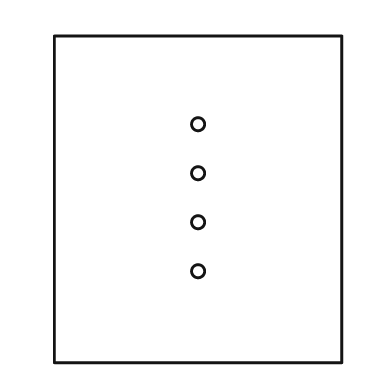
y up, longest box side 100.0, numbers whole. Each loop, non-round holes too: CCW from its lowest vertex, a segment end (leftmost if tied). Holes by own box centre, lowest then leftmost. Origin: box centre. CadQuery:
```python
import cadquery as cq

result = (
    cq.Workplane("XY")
    .moveTo(-44.0, -50.0)
    .lineTo(44.0, -50.0)
    .lineTo(44.0, 50.0)
    .lineTo(-44.0, 50.0)
    .close()
    .moveTo(0.0, -22.0)
    .circle(2.0)
    .moveTo(0.0, -7.0)
    .circle(2.0)
    .moveTo(0.0, 8.0)
    .circle(2.0)
    .moveTo(0.0, 23.0)
    .circle(2.0)
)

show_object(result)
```